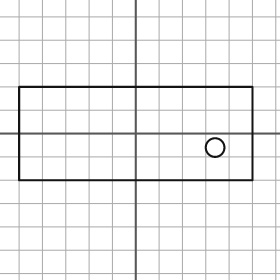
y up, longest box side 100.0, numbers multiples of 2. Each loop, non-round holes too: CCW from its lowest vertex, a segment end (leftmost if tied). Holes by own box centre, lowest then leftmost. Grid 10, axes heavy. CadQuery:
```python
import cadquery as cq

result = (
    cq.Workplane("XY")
    .moveTo(-50.0, -20.0)
    .lineTo(50.0, -20.0)
    .lineTo(50.0, 20.0)
    .lineTo(-50.0, 20.0)
    .close()
    .moveTo(34.0, -6.0)
    .circle(4.0)
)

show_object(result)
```